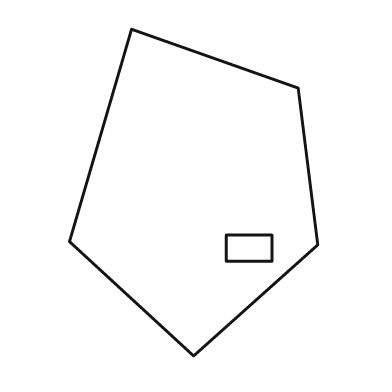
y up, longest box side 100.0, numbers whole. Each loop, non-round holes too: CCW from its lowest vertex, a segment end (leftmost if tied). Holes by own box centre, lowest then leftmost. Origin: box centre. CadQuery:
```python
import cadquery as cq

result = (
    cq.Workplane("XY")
    .moveTo(0.0, -50.0)
    .lineTo(38.0, -16.0)
    .lineTo(32.0, 32.0)
    .lineTo(-19.0, 50.0)
    .lineTo(-38.0, -15.0)
    .close()
    .moveTo(10.0, -21.0)
    .lineTo(24.0, -21.0)
    .lineTo(24.0, -13.0)
    .lineTo(10.0, -13.0)
    .close()
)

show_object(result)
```